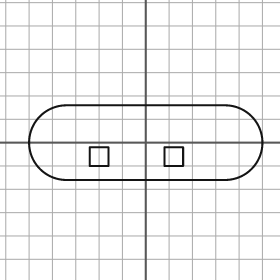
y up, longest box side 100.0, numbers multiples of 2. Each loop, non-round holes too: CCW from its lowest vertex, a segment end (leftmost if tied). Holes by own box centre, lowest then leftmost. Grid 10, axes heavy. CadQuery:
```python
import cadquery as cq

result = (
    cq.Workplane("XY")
    .moveTo(-34.0, -16.0)
    .lineTo(34.0, -16.0)
    .threePointArc((50.0, 0.0), (34.0, 16.0))
    .lineTo(-34.0, 16.0)
    .threePointArc((-50.0, 0.0), (-34.0, -16.0))
    .close()
    .moveTo(-24.0, -10.0)
    .lineTo(-16.0, -10.0)
    .lineTo(-16.0, -2.0)
    .lineTo(-24.0, -2.0)
    .close()
    .moveTo(8.0, -10.0)
    .lineTo(16.0, -10.0)
    .lineTo(16.0, -2.0)
    .lineTo(8.0, -2.0)
    .close()
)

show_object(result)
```